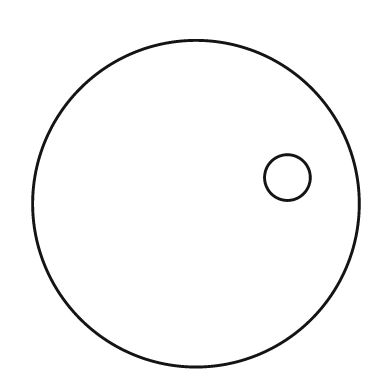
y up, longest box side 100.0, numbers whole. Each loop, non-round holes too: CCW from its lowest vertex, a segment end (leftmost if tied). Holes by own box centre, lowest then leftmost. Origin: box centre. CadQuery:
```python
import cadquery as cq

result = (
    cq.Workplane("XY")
    .moveTo(0.0, 0.0)
    .circle(50.0)
    .moveTo(28.0, 8.0)
    .circle(7.0)
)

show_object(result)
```